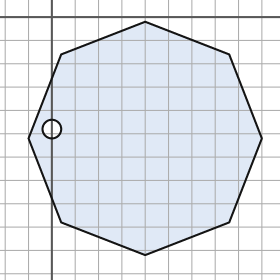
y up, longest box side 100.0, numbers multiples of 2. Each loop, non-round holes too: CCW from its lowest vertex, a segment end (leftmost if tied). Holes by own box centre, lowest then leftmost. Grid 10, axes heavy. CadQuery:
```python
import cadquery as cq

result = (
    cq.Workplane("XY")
    .moveTo(40.0, -102.0)
    .lineTo(76.0, -88.0)
    .lineTo(90.0, -52.0)
    .lineTo(76.0, -16.0)
    .lineTo(40.0, -2.0)
    .lineTo(4.0, -16.0)
    .lineTo(-10.0, -52.0)
    .lineTo(4.0, -88.0)
    .close()
    .moveTo(0.0, -48.0)
    .circle(4.0)
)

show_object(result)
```